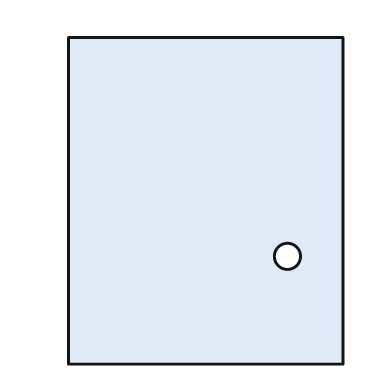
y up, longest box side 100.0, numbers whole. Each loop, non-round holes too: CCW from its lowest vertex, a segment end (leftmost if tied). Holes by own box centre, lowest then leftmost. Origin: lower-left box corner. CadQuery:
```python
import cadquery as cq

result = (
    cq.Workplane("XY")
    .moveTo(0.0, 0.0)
    .lineTo(84.0, 0.0)
    .lineTo(84.0, 100.0)
    .lineTo(0.0, 100.0)
    .close()
    .moveTo(67.0, 33.0)
    .circle(4.0)
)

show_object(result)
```